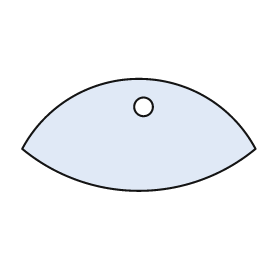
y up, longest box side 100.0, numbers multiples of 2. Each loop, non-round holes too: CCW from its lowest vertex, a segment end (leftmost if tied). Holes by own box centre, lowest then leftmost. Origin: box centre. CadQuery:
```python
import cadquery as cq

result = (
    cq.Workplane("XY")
    .moveTo(-50.0, -6.0)
    .threePointArc((0.0, -24.0), (50.0, -6.0))
    .threePointArc((0.0, 24.0), (-50.0, -6.0))
    .close()
    .moveTo(2.0, 12.0)
    .circle(4.0)
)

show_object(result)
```